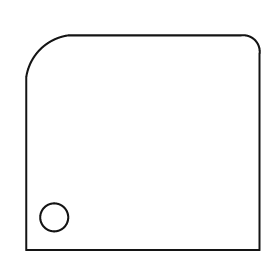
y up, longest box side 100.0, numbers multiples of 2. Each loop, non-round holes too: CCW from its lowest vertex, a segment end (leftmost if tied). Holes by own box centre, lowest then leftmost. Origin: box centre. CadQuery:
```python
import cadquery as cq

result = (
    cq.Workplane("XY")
    .moveTo(-50.0, -46.0)
    .lineTo(50.0, -46.0)
    .lineTo(50.0, 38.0)
    .threePointArc((48.0, 44.0), (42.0, 46.0))
    .lineTo(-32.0, 46.0)
    .threePointArc((-44.0, 40.0), (-50.0, 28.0))
    .close()
    .moveTo(-38.0, -32.0)
    .circle(6.0)
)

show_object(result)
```